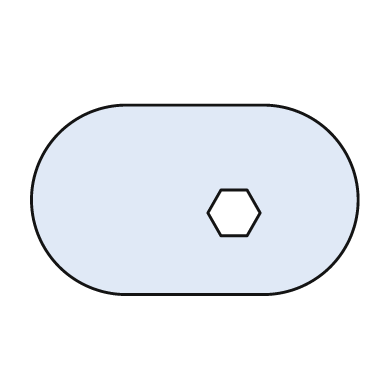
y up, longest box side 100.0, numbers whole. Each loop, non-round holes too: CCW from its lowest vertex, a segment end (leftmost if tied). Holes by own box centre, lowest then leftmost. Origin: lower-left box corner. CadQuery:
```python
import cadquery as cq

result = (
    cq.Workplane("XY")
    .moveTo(29.0, 0.0)
    .lineTo(71.0, 0.0)
    .threePointArc((100.0, 29.0), (71.0, 58.0))
    .lineTo(29.0, 58.0)
    .threePointArc((0.0, 29.0), (29.0, 0.0))
    .close()
    .moveTo(58.0, 18.0)
    .lineTo(66.0, 18.0)
    .lineTo(70.0, 25.0)
    .lineTo(66.0, 32.0)
    .lineTo(58.0, 32.0)
    .lineTo(54.0, 25.0)
    .close()
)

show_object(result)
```